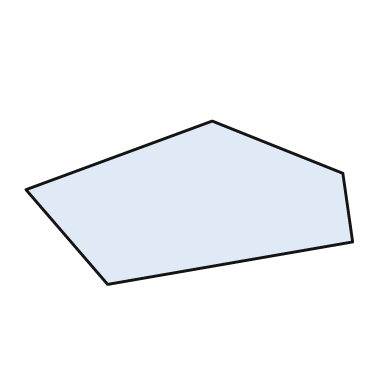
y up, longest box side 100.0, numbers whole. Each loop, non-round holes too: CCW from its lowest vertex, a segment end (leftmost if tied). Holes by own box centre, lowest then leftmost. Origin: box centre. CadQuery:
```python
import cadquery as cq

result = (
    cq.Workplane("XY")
    .moveTo(-25.0, -25.0)
    .lineTo(50.0, -12.0)
    .lineTo(47.0, 9.0)
    .lineTo(7.0, 25.0)
    .lineTo(-50.0, 4.0)
    .close()
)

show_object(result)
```